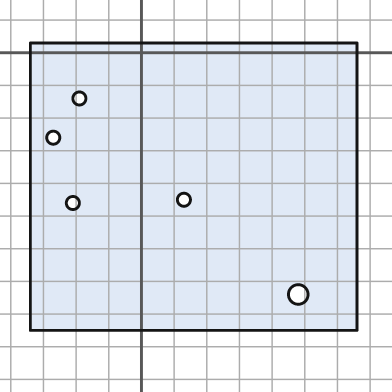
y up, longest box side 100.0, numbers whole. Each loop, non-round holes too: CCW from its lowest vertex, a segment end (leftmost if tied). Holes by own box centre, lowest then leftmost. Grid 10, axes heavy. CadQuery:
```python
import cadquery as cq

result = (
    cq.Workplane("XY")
    .moveTo(-34.0, -85.0)
    .lineTo(66.0, -85.0)
    .lineTo(66.0, 3.0)
    .lineTo(-34.0, 3.0)
    .close()
    .moveTo(48.0, -74.0)
    .circle(3.0)
    .moveTo(-21.0, -46.0)
    .circle(2.0)
    .moveTo(13.0, -45.0)
    .circle(2.0)
    .moveTo(-27.0, -26.0)
    .circle(2.0)
    .moveTo(-19.0, -14.0)
    .circle(2.0)
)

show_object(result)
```